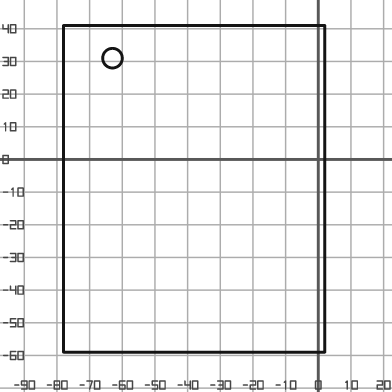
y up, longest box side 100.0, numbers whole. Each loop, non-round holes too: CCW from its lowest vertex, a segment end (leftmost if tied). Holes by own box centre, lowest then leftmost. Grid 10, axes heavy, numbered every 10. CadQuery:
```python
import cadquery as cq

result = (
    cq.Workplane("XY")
    .moveTo(-78.0, -59.0)
    .lineTo(2.0, -59.0)
    .lineTo(2.0, 41.0)
    .lineTo(-78.0, 41.0)
    .close()
    .moveTo(-63.0, 31.0)
    .circle(3.0)
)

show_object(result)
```